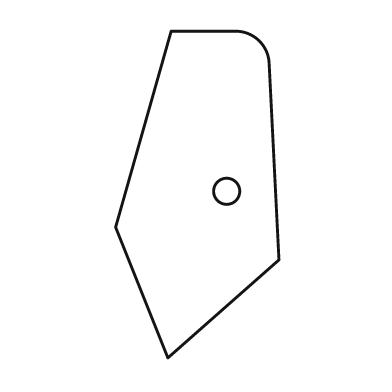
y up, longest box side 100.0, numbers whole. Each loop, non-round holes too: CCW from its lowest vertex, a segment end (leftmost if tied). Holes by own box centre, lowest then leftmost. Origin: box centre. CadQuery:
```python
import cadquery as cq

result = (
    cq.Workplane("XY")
    .moveTo(-9.0, -50.0)
    .lineTo(25.0, -20.0)
    .lineTo(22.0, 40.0)
    .threePointArc((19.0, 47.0), (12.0, 50.0))
    .lineTo(-8.0, 50.0)
    .lineTo(-25.0, -10.0)
    .close()
    .moveTo(9.0, 1.0)
    .circle(4.0)
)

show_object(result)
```